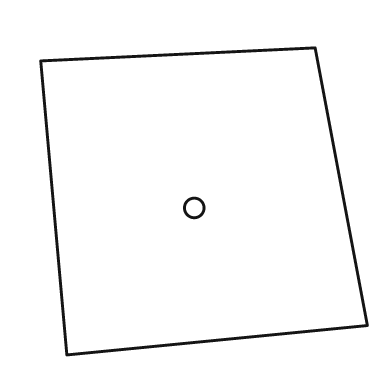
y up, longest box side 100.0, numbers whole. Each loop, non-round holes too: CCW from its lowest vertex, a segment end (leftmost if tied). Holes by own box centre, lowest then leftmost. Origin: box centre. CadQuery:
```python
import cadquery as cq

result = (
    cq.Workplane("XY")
    .moveTo(-42.0, -47.0)
    .lineTo(50.0, -38.0)
    .lineTo(34.0, 47.0)
    .lineTo(-50.0, 43.0)
    .close()
    .moveTo(-3.0, -2.0)
    .circle(3.0)
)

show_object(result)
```